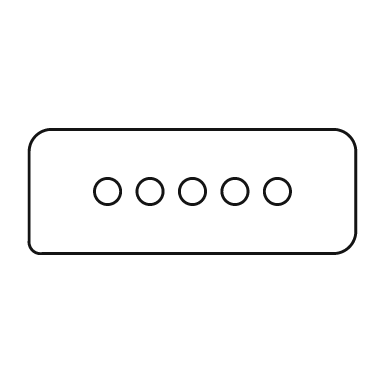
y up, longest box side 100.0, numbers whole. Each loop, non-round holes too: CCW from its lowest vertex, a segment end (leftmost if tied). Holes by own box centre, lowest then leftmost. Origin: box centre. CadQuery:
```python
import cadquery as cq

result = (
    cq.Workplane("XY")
    .moveTo(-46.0, -19.0)
    .lineTo(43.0, -19.0)
    .threePointArc((48.0, -17.0), (50.0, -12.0))
    .lineTo(50.0, 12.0)
    .threePointArc((48.0, 17.0), (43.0, 19.0))
    .lineTo(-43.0, 19.0)
    .threePointArc((-48.0, 17.0), (-50.0, 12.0))
    .lineTo(-50.0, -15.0)
    .threePointArc((-49.0, -18.0), (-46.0, -19.0))
    .close()
    .moveTo(-26.0, 0.0)
    .circle(4.0)
    .moveTo(-13.0, 0.0)
    .circle(4.0)
    .moveTo(0.0, 0.0)
    .circle(4.0)
    .moveTo(13.0, 0.0)
    .circle(4.0)
    .moveTo(26.0, 0.0)
    .circle(4.0)
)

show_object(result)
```